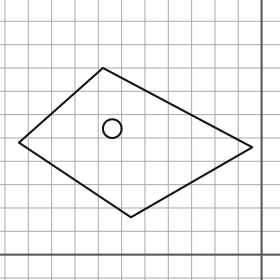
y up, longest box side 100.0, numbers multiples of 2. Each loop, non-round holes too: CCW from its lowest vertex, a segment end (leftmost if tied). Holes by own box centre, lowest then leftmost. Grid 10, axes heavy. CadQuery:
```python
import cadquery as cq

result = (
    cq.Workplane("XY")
    .moveTo(-56.0, 16.0)
    .lineTo(-4.0, 46.0)
    .lineTo(-68.0, 80.0)
    .lineTo(-104.0, 48.0)
    .close()
    .moveTo(-64.0, 54.0)
    .circle(4.0)
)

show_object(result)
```